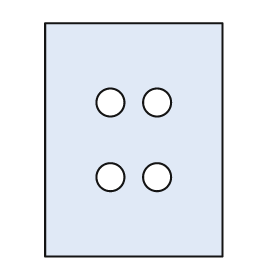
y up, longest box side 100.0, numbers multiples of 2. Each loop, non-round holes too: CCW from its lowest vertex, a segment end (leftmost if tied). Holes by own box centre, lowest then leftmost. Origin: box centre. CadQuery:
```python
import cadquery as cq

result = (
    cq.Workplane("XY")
    .moveTo(-38.0, -50.0)
    .lineTo(38.0, -50.0)
    .lineTo(38.0, 50.0)
    .lineTo(-38.0, 50.0)
    .close()
    .moveTo(-10.0, -16.0)
    .circle(6.0)
    .moveTo(10.0, -16.0)
    .circle(6.0)
    .moveTo(-10.0, 16.0)
    .circle(6.0)
    .moveTo(10.0, 16.0)
    .circle(6.0)
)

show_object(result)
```